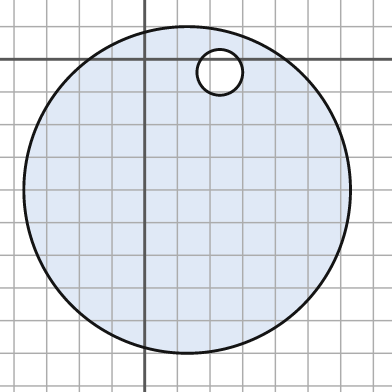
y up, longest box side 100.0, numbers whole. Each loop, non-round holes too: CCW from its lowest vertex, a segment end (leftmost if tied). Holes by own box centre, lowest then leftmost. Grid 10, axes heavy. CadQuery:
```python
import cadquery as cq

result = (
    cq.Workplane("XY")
    .moveTo(13.0, -40.0)
    .circle(50.0)
    .moveTo(23.0, -4.0)
    .circle(7.0)
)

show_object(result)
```